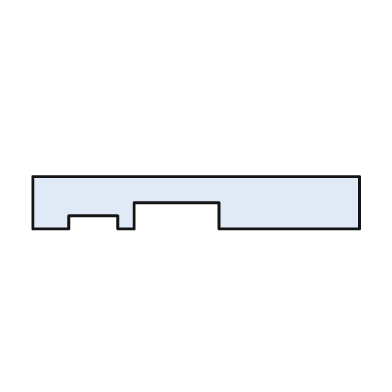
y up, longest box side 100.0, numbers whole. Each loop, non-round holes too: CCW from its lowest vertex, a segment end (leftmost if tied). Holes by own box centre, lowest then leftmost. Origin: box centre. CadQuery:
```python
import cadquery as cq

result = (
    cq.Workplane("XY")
    .moveTo(-50.0, -8.0)
    .lineTo(-39.0, -8.0)
    .lineTo(-39.0, -4.0)
    .lineTo(-24.0, -4.0)
    .lineTo(-24.0, -8.0)
    .lineTo(-19.0, -8.0)
    .lineTo(-19.0, 0.0)
    .lineTo(7.0, 0.0)
    .lineTo(7.0, -8.0)
    .lineTo(50.0, -8.0)
    .lineTo(50.0, 8.0)
    .lineTo(-50.0, 8.0)
    .close()
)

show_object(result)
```